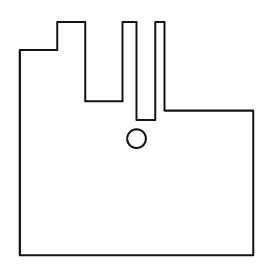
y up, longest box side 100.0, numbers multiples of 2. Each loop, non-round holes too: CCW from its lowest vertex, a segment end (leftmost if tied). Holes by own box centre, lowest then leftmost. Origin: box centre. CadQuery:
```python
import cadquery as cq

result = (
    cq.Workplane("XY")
    .moveTo(-50.0, -50.0)
    .lineTo(50.0, -50.0)
    .lineTo(50.0, 12.0)
    .lineTo(12.0, 12.0)
    .lineTo(12.0, 50.0)
    .lineTo(8.0, 50.0)
    .lineTo(8.0, 8.0)
    .lineTo(0.0, 8.0)
    .lineTo(0.0, 50.0)
    .lineTo(-6.0, 50.0)
    .lineTo(-6.0, 16.0)
    .lineTo(-22.0, 16.0)
    .lineTo(-22.0, 50.0)
    .lineTo(-34.0, 50.0)
    .lineTo(-34.0, 38.0)
    .lineTo(-50.0, 38.0)
    .close()
    .moveTo(0.0, 0.0)
    .circle(4.0)
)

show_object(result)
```